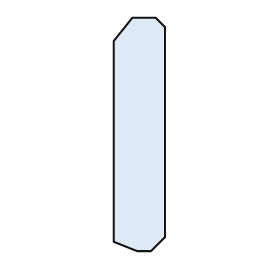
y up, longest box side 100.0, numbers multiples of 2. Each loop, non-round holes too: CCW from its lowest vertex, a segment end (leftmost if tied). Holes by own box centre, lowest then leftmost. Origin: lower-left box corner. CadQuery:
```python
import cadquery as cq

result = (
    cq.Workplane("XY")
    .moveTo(10.0, 0.0)
    .lineTo(16.0, 0.0)
    .lineTo(22.0, 6.0)
    .lineTo(22.0, 96.0)
    .lineTo(18.0, 100.0)
    .lineTo(8.0, 100.0)
    .lineTo(0.0, 90.0)
    .lineTo(0.0, 4.0)
    .close()
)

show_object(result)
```